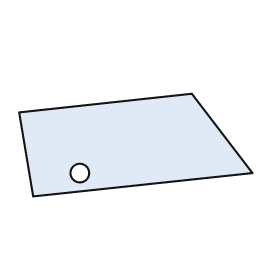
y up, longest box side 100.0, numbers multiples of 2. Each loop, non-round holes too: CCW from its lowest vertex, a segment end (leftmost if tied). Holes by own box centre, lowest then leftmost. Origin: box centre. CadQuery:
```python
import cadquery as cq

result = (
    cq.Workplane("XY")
    .moveTo(-44.0, -22.0)
    .lineTo(50.0, -12.0)
    .lineTo(24.0, 22.0)
    .lineTo(-50.0, 14.0)
    .close()
    .moveTo(-24.0, -12.0)
    .circle(4.0)
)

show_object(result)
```